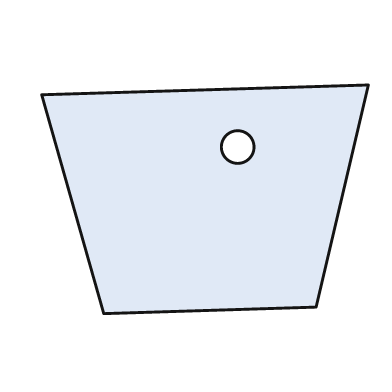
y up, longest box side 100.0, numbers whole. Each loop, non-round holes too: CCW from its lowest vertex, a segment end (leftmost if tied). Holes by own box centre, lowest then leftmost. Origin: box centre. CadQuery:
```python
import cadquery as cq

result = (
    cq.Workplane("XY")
    .moveTo(-31.0, -35.0)
    .lineTo(34.0, -33.0)
    .lineTo(50.0, 35.0)
    .lineTo(-50.0, 32.0)
    .close()
    .moveTo(10.0, 16.0)
    .circle(5.0)
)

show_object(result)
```